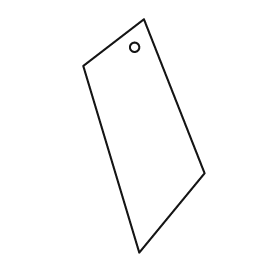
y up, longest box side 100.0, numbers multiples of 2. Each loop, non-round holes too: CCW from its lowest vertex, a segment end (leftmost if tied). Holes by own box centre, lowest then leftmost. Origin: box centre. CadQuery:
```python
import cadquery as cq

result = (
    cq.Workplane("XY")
    .moveTo(-2.0, -50.0)
    .lineTo(26.0, -16.0)
    .lineTo(0.0, 50.0)
    .lineTo(-26.0, 30.0)
    .close()
    .moveTo(-4.0, 38.0)
    .circle(2.0)
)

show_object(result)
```